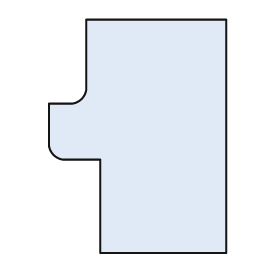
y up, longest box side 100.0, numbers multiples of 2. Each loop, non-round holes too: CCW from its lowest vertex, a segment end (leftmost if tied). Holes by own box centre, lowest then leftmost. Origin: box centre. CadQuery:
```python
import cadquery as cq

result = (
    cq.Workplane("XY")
    .moveTo(-16.0, -50.0)
    .lineTo(38.0, -50.0)
    .lineTo(38.0, 50.0)
    .lineTo(-22.0, 50.0)
    .lineTo(-22.0, 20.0)
    .threePointArc((-24.0, 16.0), (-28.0, 14.0))
    .lineTo(-38.0, 14.0)
    .lineTo(-38.0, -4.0)
    .threePointArc((-36.0, -8.0), (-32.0, -10.0))
    .lineTo(-16.0, -10.0)
    .close()
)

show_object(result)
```